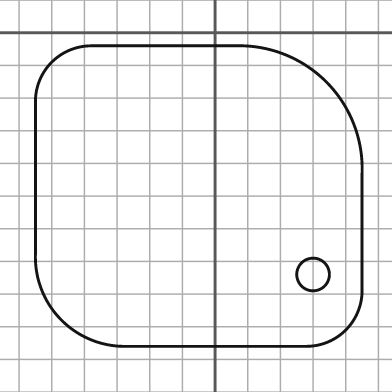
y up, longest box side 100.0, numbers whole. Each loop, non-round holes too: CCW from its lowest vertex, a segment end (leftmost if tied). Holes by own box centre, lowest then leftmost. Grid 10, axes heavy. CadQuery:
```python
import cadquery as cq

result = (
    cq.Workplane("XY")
    .moveTo(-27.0, -96.0)
    .lineTo(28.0, -96.0)
    .threePointArc((40.0, -91.0), (45.0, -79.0))
    .lineTo(45.0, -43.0)
    .threePointArc((34.0, -15.0), (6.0, -4.0))
    .lineTo(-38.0, -4.0)
    .threePointArc((-50.0, -9.0), (-55.0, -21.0))
    .lineTo(-55.0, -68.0)
    .threePointArc((-47.0, -88.0), (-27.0, -96.0))
    .close()
    .moveTo(30.0, -74.0)
    .circle(5.0)
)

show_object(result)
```